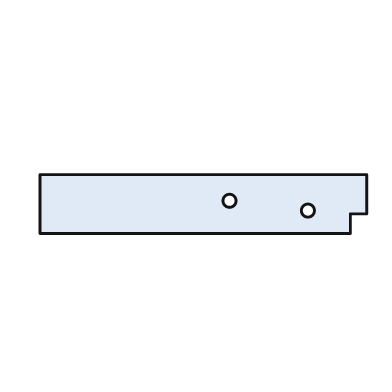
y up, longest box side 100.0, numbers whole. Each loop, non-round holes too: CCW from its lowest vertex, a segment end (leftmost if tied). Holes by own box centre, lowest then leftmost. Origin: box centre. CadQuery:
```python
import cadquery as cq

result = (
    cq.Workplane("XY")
    .moveTo(-50.0, -9.0)
    .lineTo(45.0, -9.0)
    .lineTo(45.0, -3.0)
    .lineTo(50.0, -3.0)
    .lineTo(50.0, 9.0)
    .lineTo(-50.0, 9.0)
    .close()
    .moveTo(32.0, -2.0)
    .circle(2.0)
    .moveTo(8.0, 1.0)
    .circle(2.0)
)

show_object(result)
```